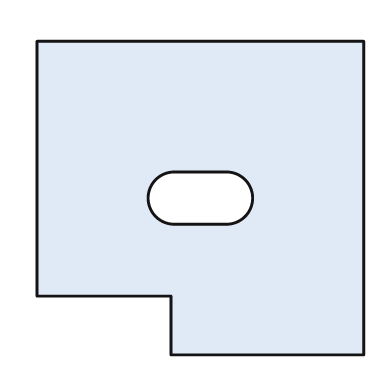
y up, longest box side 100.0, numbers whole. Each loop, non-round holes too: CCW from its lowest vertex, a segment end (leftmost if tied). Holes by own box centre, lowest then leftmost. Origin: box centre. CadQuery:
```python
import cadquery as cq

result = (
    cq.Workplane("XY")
    .moveTo(-9.0, -48.0)
    .lineTo(50.0, -48.0)
    .lineTo(50.0, 48.0)
    .lineTo(-50.0, 48.0)
    .lineTo(-50.0, -30.0)
    .lineTo(-9.0, -30.0)
    .close()
    .moveTo(-8.0, -8.0)
    .lineTo(8.0, -8.0)
    .threePointArc((16.0, 0.0), (8.0, 8.0))
    .lineTo(-8.0, 8.0)
    .threePointArc((-16.0, 0.0), (-8.0, -8.0))
    .close()
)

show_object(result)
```